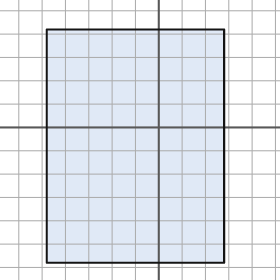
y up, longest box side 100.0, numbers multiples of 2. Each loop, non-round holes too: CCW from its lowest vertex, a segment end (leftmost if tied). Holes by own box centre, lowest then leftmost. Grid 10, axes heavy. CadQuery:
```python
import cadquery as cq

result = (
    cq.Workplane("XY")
    .moveTo(-48.0, -58.0)
    .lineTo(28.0, -58.0)
    .lineTo(28.0, 42.0)
    .lineTo(-48.0, 42.0)
    .close()
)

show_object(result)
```